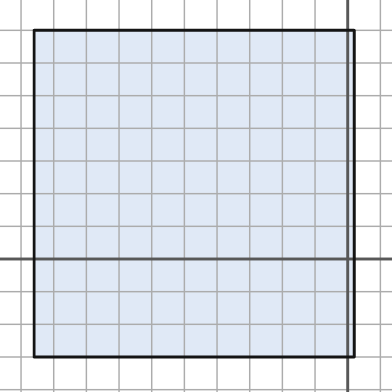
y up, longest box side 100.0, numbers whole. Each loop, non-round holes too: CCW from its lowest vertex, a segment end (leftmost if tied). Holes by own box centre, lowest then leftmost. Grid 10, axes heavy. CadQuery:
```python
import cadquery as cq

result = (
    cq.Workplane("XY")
    .moveTo(-96.0, -30.0)
    .lineTo(2.0, -30.0)
    .lineTo(2.0, 70.0)
    .lineTo(-96.0, 70.0)
    .close()
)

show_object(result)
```